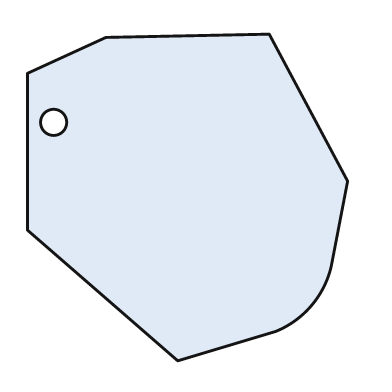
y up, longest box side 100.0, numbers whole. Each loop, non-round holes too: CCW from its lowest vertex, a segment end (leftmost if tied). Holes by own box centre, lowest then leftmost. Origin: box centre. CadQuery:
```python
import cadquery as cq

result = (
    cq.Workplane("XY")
    .moveTo(-3.0, -50.0)
    .lineTo(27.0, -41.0)
    .threePointArc((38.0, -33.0), (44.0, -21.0))
    .lineTo(49.0, 5.0)
    .lineTo(25.0, 50.0)
    .lineTo(-25.0, 49.0)
    .lineTo(-49.0, 38.0)
    .lineTo(-49.0, -10.0)
    .close()
    .moveTo(-41.0, 23.0)
    .circle(4.0)
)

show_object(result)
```